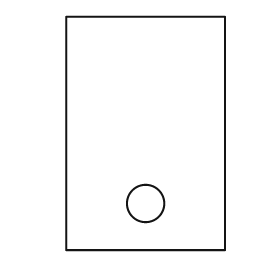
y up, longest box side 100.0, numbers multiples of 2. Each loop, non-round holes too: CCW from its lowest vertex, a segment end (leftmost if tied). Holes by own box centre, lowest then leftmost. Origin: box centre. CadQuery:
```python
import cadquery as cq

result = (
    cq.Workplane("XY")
    .moveTo(-34.0, -50.0)
    .lineTo(34.0, -50.0)
    .lineTo(34.0, 50.0)
    .lineTo(-34.0, 50.0)
    .close()
    .moveTo(0.0, -30.0)
    .circle(8.0)
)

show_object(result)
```